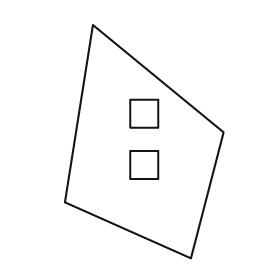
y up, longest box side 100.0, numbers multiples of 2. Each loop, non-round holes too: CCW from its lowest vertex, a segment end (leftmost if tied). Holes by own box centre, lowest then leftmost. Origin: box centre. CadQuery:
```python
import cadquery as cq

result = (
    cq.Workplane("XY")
    .moveTo(20.0, -50.0)
    .lineTo(34.0, 4.0)
    .lineTo(-22.0, 50.0)
    .lineTo(-34.0, -26.0)
    .close()
    .moveTo(-6.0, -16.0)
    .lineTo(6.0, -16.0)
    .lineTo(6.0, -4.0)
    .lineTo(-6.0, -4.0)
    .close()
    .moveTo(-6.0, 6.0)
    .lineTo(6.0, 6.0)
    .lineTo(6.0, 18.0)
    .lineTo(-6.0, 18.0)
    .close()
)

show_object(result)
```